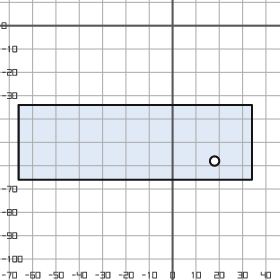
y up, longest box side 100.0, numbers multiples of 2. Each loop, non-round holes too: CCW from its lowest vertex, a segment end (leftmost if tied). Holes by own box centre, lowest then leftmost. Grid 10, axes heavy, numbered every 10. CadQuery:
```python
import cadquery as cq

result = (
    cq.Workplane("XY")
    .moveTo(-66.0, -66.0)
    .lineTo(34.0, -66.0)
    .lineTo(34.0, -34.0)
    .lineTo(-66.0, -34.0)
    .close()
    .moveTo(18.0, -58.0)
    .circle(2.0)
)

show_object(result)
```